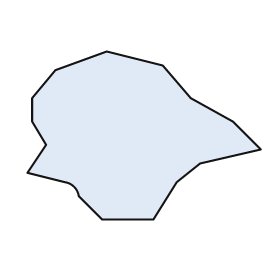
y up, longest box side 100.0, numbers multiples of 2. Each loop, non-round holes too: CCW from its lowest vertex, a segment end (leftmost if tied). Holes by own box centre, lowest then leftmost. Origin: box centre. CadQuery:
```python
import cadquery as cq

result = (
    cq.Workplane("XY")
    .moveTo(-18.0, -36.0)
    .lineTo(4.0, -36.0)
    .lineTo(14.0, -20.0)
    .lineTo(24.0, -12.0)
    .lineTo(50.0, -6.0)
    .lineTo(38.0, 6.0)
    .lineTo(20.0, 16.0)
    .lineTo(8.0, 30.0)
    .lineTo(-16.0, 36.0)
    .lineTo(-38.0, 28.0)
    .lineTo(-48.0, 16.0)
    .lineTo(-48.0, 6.0)
    .lineTo(-42.0, -4.0)
    .lineTo(-50.0, -16.0)
    .lineTo(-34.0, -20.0)
    .threePointArc((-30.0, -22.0), (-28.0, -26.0))
    .close()
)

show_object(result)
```